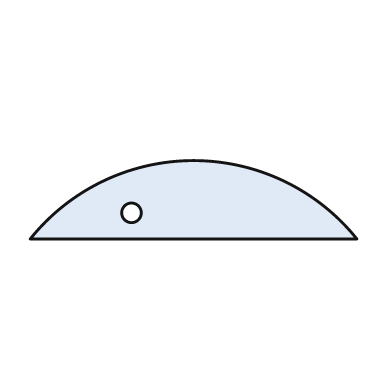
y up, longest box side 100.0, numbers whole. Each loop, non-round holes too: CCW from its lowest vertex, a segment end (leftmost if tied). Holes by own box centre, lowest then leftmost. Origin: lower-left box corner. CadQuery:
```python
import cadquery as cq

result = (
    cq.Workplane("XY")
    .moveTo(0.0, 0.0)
    .lineTo(100.0, 0.0)
    .threePointArc((50.0, 24.0), (0.0, 0.0))
    .close()
    .moveTo(31.0, 8.0)
    .circle(3.0)
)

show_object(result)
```